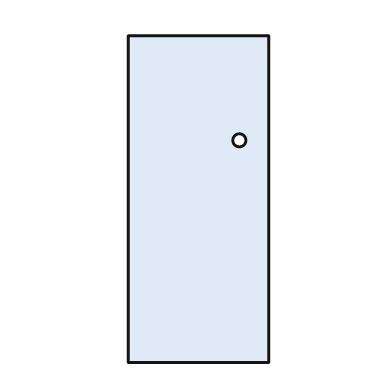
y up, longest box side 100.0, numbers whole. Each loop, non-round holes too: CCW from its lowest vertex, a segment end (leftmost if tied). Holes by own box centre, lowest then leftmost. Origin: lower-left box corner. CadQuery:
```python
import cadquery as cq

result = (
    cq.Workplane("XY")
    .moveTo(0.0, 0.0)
    .lineTo(43.0, 0.0)
    .lineTo(43.0, 100.0)
    .lineTo(0.0, 100.0)
    .close()
    .moveTo(34.0, 68.0)
    .circle(2.0)
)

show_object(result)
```